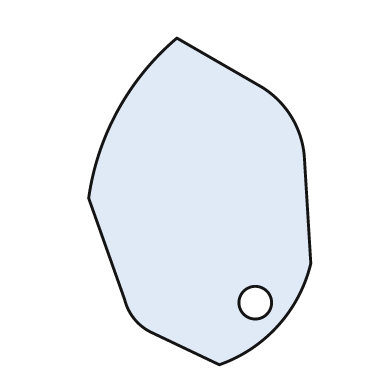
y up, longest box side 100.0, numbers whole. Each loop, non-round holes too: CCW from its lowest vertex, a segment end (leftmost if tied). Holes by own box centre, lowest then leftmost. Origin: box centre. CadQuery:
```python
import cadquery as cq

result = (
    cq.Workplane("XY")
    .moveTo(6.0, -50.0)
    .threePointArc((24.0, -38.0), (34.0, -19.0))
    .lineTo(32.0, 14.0)
    .threePointArc((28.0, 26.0), (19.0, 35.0))
    .lineTo(-7.0, 50.0)
    .threePointArc((-25.0, 28.0), (-34.0, 1.0))
    .lineTo(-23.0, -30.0)
    .threePointArc((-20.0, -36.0), (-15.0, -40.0))
    .close()
    .moveTo(17.0, -31.0)
    .circle(5.0)
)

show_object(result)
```